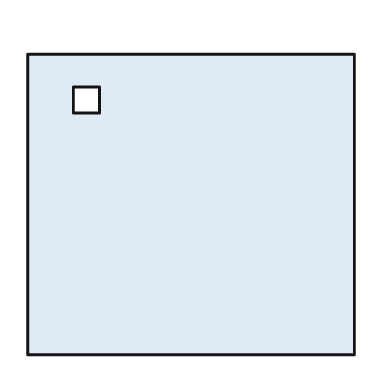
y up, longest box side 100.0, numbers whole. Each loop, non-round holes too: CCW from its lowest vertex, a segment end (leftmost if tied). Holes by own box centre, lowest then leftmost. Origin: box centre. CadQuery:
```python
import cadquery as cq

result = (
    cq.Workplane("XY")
    .moveTo(-50.0, -46.0)
    .lineTo(50.0, -46.0)
    .lineTo(50.0, 46.0)
    .lineTo(-50.0, 46.0)
    .close()
    .moveTo(-36.0, 28.0)
    .lineTo(-28.0, 28.0)
    .lineTo(-28.0, 36.0)
    .lineTo(-36.0, 36.0)
    .close()
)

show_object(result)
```